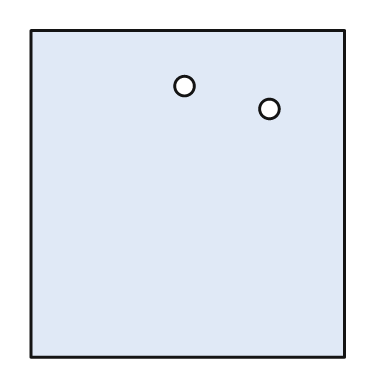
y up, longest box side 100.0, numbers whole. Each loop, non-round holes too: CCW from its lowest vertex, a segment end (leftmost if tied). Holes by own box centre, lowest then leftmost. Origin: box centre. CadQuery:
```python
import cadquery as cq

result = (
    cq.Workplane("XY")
    .moveTo(-48.0, -50.0)
    .lineTo(48.0, -50.0)
    .lineTo(48.0, 50.0)
    .lineTo(-48.0, 50.0)
    .close()
    .moveTo(25.0, 26.0)
    .circle(3.0)
    .moveTo(-1.0, 33.0)
    .circle(3.0)
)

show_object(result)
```